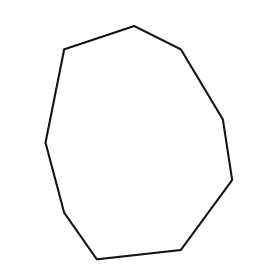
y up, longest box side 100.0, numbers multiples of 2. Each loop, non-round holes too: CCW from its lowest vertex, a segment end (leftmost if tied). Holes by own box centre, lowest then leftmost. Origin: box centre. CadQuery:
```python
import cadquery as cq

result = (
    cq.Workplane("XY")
    .moveTo(-18.0, -50.0)
    .lineTo(18.0, -46.0)
    .lineTo(40.0, -16.0)
    .lineTo(36.0, 10.0)
    .lineTo(18.0, 40.0)
    .lineTo(-2.0, 50.0)
    .lineTo(-32.0, 40.0)
    .lineTo(-40.0, 0.0)
    .lineTo(-32.0, -30.0)
    .close()
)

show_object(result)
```